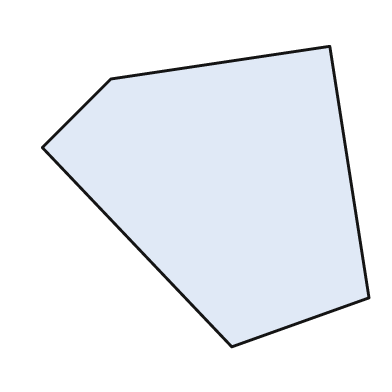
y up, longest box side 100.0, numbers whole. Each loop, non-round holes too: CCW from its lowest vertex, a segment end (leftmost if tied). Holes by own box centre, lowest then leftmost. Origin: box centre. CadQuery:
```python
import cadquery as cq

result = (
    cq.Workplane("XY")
    .moveTo(8.0, -46.0)
    .lineTo(50.0, -31.0)
    .lineTo(38.0, 46.0)
    .lineTo(-29.0, 36.0)
    .lineTo(-50.0, 15.0)
    .close()
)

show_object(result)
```